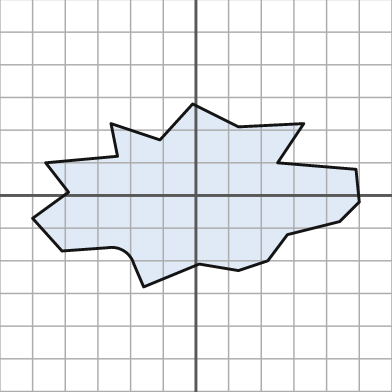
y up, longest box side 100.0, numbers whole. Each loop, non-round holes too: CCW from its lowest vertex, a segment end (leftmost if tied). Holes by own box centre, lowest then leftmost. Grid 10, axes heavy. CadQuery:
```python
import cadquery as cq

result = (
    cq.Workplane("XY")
    .moveTo(-16.0, -28.0)
    .lineTo(1.0, -21.0)
    .lineTo(13.0, -23.0)
    .lineTo(22.0, -20.0)
    .lineTo(28.0, -12.0)
    .lineTo(44.0, -8.0)
    .lineTo(50.0, -2.0)
    .lineTo(49.0, 8.0)
    .lineTo(25.0, 10.0)
    .lineTo(33.0, 22.0)
    .lineTo(13.0, 21.0)
    .lineTo(-1.0, 28.0)
    .lineTo(-11.0, 17.0)
    .lineTo(-26.0, 22.0)
    .lineTo(-24.0, 12.0)
    .lineTo(-46.0, 10.0)
    .lineTo(-39.0, 1.0)
    .lineTo(-50.0, -7.0)
    .lineTo(-41.0, -17.0)
    .lineTo(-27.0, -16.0)
    .threePointArc((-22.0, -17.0), (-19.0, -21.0))
    .close()
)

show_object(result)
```